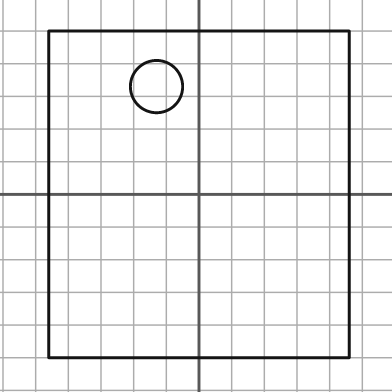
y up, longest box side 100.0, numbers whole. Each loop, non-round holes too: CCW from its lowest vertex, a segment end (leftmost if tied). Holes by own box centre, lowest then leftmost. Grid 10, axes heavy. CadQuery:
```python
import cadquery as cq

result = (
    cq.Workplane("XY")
    .moveTo(-46.0, -50.0)
    .lineTo(46.0, -50.0)
    .lineTo(46.0, 50.0)
    .lineTo(-46.0, 50.0)
    .close()
    .moveTo(-13.0, 33.0)
    .circle(8.0)
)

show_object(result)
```